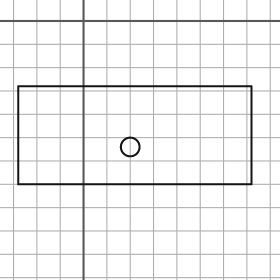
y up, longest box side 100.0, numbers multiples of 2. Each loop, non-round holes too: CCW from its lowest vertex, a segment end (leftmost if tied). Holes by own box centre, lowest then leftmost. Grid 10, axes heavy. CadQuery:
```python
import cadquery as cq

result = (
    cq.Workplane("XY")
    .moveTo(-28.0, -70.0)
    .lineTo(72.0, -70.0)
    .lineTo(72.0, -28.0)
    .lineTo(-28.0, -28.0)
    .close()
    .moveTo(20.0, -54.0)
    .circle(4.0)
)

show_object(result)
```